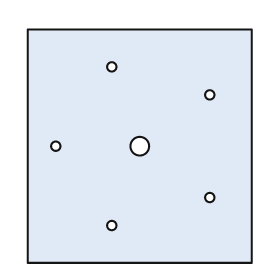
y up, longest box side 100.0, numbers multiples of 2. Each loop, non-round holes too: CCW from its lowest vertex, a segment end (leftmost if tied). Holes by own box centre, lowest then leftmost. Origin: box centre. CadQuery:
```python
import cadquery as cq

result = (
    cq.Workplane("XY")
    .moveTo(-48.0, -50.0)
    .lineTo(48.0, -50.0)
    .lineTo(48.0, 50.0)
    .lineTo(-48.0, 50.0)
    .close()
    .moveTo(-12.0, -34.0)
    .circle(2.0)
    .moveTo(30.0, -22.0)
    .circle(2.0)
    .moveTo(-36.0, 0.0)
    .circle(2.0)
    .moveTo(0.0, 0.0)
    .circle(4.0)
    .moveTo(30.0, 22.0)
    .circle(2.0)
    .moveTo(-12.0, 34.0)
    .circle(2.0)
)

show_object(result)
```